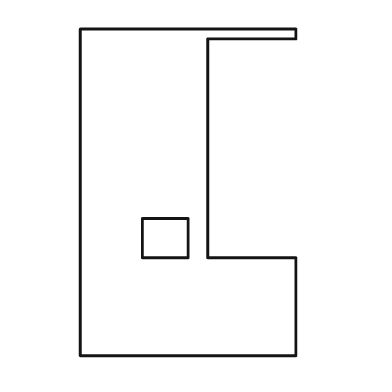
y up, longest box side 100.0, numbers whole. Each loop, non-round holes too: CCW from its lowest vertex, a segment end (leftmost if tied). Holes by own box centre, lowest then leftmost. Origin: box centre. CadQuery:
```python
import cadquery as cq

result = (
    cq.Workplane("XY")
    .moveTo(-33.0, -50.0)
    .lineTo(33.0, -50.0)
    .lineTo(33.0, -20.0)
    .lineTo(6.0, -20.0)
    .lineTo(6.0, 47.0)
    .lineTo(33.0, 47.0)
    .lineTo(33.0, 50.0)
    .lineTo(-33.0, 50.0)
    .close()
    .moveTo(-14.0, -20.0)
    .lineTo(0.0, -20.0)
    .lineTo(0.0, -8.0)
    .lineTo(-14.0, -8.0)
    .close()
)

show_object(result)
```